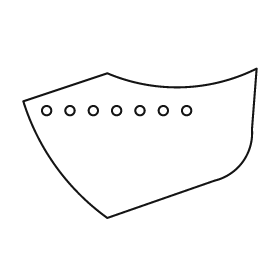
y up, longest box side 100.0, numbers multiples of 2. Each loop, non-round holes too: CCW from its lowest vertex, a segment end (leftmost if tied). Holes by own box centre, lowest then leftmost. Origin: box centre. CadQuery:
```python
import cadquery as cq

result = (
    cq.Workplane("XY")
    .moveTo(-14.0, -32.0)
    .lineTo(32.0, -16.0)
    .threePointArc((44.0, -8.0), (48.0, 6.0))
    .lineTo(50.0, 32.0)
    .threePointArc((18.0, 24.0), (-14.0, 30.0))
    .lineTo(-50.0, 18.0)
    .threePointArc((-36.0, -10.0), (-14.0, -32.0))
    .close()
    .moveTo(-40.0, 14.0)
    .circle(2.0)
    .moveTo(-30.0, 14.0)
    .circle(2.0)
    .moveTo(-20.0, 14.0)
    .circle(2.0)
    .moveTo(-10.0, 14.0)
    .circle(2.0)
    .moveTo(0.0, 14.0)
    .circle(2.0)
    .moveTo(10.0, 14.0)
    .circle(2.0)
    .moveTo(20.0, 14.0)
    .circle(2.0)
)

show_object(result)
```